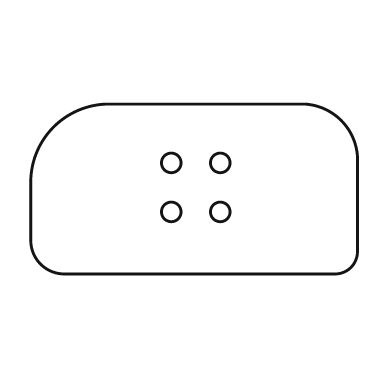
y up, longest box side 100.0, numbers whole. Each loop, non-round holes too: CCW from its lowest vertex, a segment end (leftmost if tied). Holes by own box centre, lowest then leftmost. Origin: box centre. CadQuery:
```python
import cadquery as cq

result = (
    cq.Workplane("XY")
    .moveTo(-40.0, -26.0)
    .lineTo(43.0, -26.0)
    .threePointArc((48.0, -24.0), (50.0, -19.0))
    .lineTo(50.0, 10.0)
    .threePointArc((45.0, 21.0), (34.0, 26.0))
    .lineTo(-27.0, 26.0)
    .threePointArc((-43.0, 19.0), (-50.0, 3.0))
    .lineTo(-50.0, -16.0)
    .threePointArc((-47.0, -23.0), (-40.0, -26.0))
    .close()
    .moveTo(-7.0, -7.0)
    .circle(3.0)
    .moveTo(8.0, -7.0)
    .circle(3.0)
    .moveTo(-7.0, 8.0)
    .circle(3.0)
    .moveTo(8.0, 8.0)
    .circle(3.0)
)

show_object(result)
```